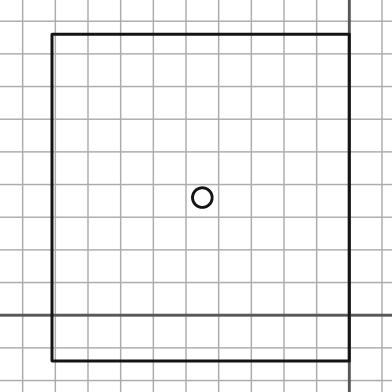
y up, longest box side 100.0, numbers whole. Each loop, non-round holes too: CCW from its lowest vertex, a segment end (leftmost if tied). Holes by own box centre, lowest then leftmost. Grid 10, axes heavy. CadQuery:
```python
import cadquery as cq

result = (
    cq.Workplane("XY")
    .moveTo(-91.0, -14.0)
    .lineTo(0.0, -14.0)
    .lineTo(0.0, 86.0)
    .lineTo(-91.0, 86.0)
    .close()
    .moveTo(-45.0, 36.0)
    .circle(3.0)
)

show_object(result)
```